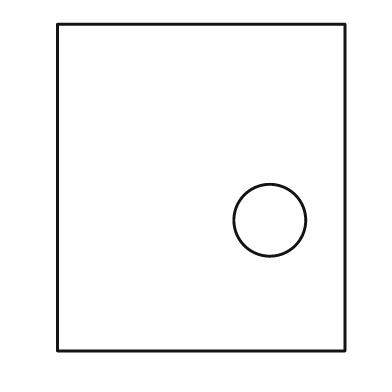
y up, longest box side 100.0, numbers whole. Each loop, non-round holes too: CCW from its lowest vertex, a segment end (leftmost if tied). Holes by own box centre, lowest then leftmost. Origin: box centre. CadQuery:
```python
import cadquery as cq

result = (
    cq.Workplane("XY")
    .moveTo(-44.0, -50.0)
    .lineTo(44.0, -50.0)
    .lineTo(44.0, 50.0)
    .lineTo(-44.0, 50.0)
    .close()
    .moveTo(21.0, -10.0)
    .circle(11.0)
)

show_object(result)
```